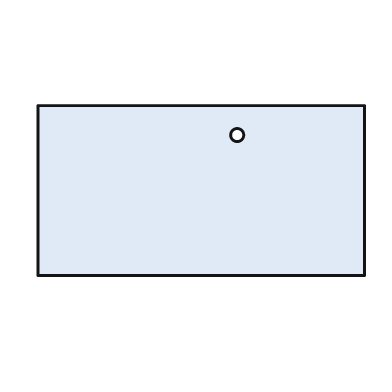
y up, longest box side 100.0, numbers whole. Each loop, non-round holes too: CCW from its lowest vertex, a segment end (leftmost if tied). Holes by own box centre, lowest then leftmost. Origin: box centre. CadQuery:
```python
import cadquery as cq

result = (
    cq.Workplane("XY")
    .moveTo(-50.0, -26.0)
    .lineTo(50.0, -26.0)
    .lineTo(50.0, 26.0)
    .lineTo(-50.0, 26.0)
    .close()
    .moveTo(11.0, 17.0)
    .circle(2.0)
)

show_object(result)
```